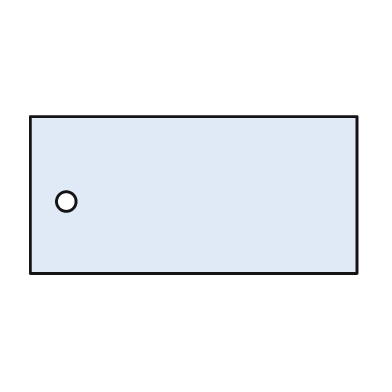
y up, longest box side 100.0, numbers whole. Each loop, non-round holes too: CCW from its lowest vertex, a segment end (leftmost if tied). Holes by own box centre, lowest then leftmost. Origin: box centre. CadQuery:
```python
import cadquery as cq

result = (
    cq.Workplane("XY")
    .moveTo(-50.0, -24.0)
    .lineTo(50.0, -24.0)
    .lineTo(50.0, 24.0)
    .lineTo(-50.0, 24.0)
    .close()
    .moveTo(-39.0, -2.0)
    .circle(3.0)
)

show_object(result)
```